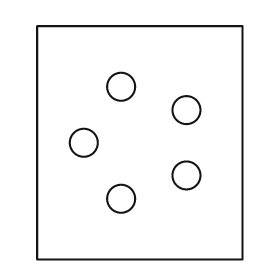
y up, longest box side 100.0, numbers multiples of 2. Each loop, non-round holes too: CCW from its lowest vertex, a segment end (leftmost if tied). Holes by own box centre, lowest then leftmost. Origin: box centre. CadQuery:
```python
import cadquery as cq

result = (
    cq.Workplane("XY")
    .moveTo(-44.0, -50.0)
    .lineTo(44.0, -50.0)
    .lineTo(44.0, 50.0)
    .lineTo(-44.0, 50.0)
    .close()
    .moveTo(-8.0, -24.0)
    .circle(6.0)
    .moveTo(20.0, -14.0)
    .circle(6.0)
    .moveTo(-24.0, 0.0)
    .circle(6.0)
    .moveTo(20.0, 14.0)
    .circle(6.0)
    .moveTo(-8.0, 24.0)
    .circle(6.0)
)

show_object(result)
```